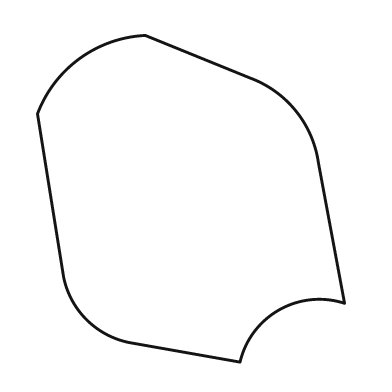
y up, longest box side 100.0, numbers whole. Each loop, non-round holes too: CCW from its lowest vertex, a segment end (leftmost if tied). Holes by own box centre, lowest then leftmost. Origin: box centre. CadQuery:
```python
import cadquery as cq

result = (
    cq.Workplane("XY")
    .moveTo(15.0, -50.0)
    .threePointArc((27.0, -34.0), (47.0, -32.0))
    .lineTo(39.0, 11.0)
    .threePointArc((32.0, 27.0), (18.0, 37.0))
    .lineTo(-14.0, 50.0)
    .threePointArc((-34.0, 43.0), (-47.0, 26.0))
    .lineTo(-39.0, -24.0)
    .threePointArc((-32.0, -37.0), (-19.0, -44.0))
    .close()
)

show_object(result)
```